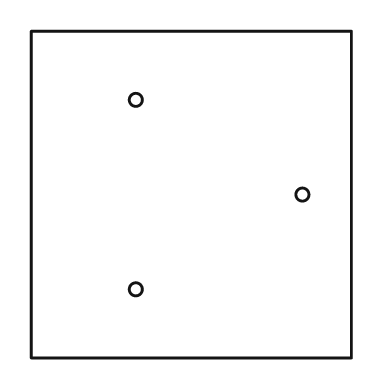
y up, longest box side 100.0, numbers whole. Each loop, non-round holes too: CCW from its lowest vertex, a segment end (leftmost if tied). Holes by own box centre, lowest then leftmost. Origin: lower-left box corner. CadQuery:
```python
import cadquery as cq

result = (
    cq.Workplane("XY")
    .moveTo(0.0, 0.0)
    .lineTo(98.0, 0.0)
    .lineTo(98.0, 100.0)
    .lineTo(0.0, 100.0)
    .close()
    .moveTo(32.0, 21.0)
    .circle(2.0)
    .moveTo(83.0, 50.0)
    .circle(2.0)
    .moveTo(32.0, 79.0)
    .circle(2.0)
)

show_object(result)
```